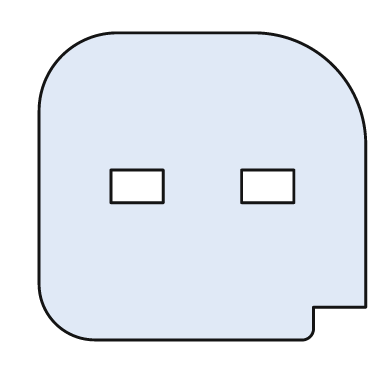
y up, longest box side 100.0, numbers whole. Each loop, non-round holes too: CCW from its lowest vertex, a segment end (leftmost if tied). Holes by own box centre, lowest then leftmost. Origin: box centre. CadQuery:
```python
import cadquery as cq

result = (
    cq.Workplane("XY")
    .moveTo(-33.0, -47.0)
    .lineTo(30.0, -47.0)
    .threePointArc((33.0, -46.0), (34.0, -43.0))
    .lineTo(34.0, -37.0)
    .lineTo(50.0, -37.0)
    .lineTo(50.0, 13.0)
    .threePointArc((40.0, 37.0), (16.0, 47.0))
    .lineTo(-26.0, 47.0)
    .threePointArc((-43.0, 40.0), (-50.0, 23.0))
    .lineTo(-50.0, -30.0)
    .threePointArc((-45.0, -42.0), (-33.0, -47.0))
    .close()
    .moveTo(-28.0, -5.0)
    .lineTo(-12.0, -5.0)
    .lineTo(-12.0, 5.0)
    .lineTo(-28.0, 5.0)
    .close()
    .moveTo(12.0, -5.0)
    .lineTo(28.0, -5.0)
    .lineTo(28.0, 5.0)
    .lineTo(12.0, 5.0)
    .close()
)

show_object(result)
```